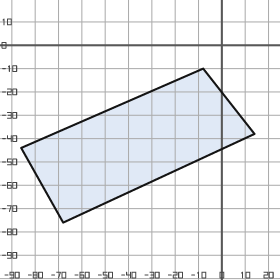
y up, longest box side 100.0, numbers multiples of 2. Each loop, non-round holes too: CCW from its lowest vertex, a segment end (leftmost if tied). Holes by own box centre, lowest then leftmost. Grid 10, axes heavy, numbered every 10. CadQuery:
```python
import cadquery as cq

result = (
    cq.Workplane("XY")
    .moveTo(-68.0, -76.0)
    .lineTo(14.0, -38.0)
    .lineTo(-8.0, -10.0)
    .lineTo(-86.0, -44.0)
    .close()
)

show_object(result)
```